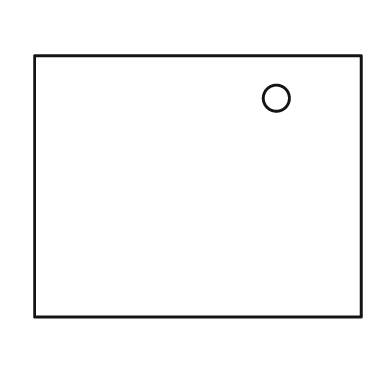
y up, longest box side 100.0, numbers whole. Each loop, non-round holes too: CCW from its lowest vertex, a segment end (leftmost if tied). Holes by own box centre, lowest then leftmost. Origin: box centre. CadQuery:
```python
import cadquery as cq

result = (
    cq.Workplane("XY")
    .moveTo(-50.0, -40.0)
    .lineTo(50.0, -40.0)
    .lineTo(50.0, 40.0)
    .lineTo(-50.0, 40.0)
    .close()
    .moveTo(24.0, 27.0)
    .circle(4.0)
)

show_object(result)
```